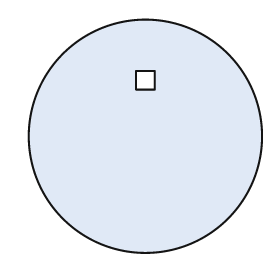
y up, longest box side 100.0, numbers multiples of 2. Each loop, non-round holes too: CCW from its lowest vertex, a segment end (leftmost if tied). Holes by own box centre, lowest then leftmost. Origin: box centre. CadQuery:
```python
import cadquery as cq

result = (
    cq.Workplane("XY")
    .moveTo(0.0, 0.0)
    .circle(50.0)
    .moveTo(-4.0, 20.0)
    .lineTo(4.0, 20.0)
    .lineTo(4.0, 28.0)
    .lineTo(-4.0, 28.0)
    .close()
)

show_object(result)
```